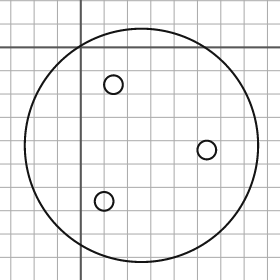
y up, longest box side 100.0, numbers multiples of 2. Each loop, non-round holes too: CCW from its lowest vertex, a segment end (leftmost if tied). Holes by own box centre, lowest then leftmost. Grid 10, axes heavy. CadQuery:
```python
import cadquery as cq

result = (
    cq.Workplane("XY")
    .moveTo(26.0, -42.0)
    .circle(50.0)
    .moveTo(10.0, -66.0)
    .circle(4.0)
    .moveTo(54.0, -44.0)
    .circle(4.0)
    .moveTo(14.0, -16.0)
    .circle(4.0)
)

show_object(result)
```